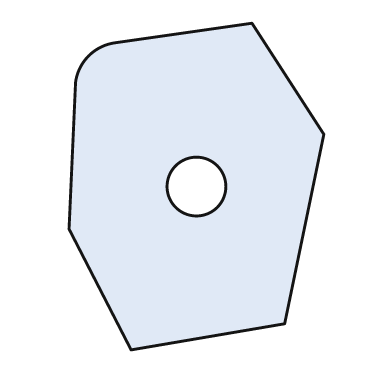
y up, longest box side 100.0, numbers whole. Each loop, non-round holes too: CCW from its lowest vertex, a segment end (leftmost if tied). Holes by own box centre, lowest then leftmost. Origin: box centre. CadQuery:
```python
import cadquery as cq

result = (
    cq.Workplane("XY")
    .moveTo(-20.0, -50.0)
    .lineTo(27.0, -42.0)
    .lineTo(39.0, 16.0)
    .lineTo(17.0, 50.0)
    .lineTo(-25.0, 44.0)
    .threePointArc((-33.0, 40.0), (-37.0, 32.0))
    .lineTo(-39.0, -13.0)
    .close()
    .moveTo(0.0, 0.0)
    .circle(9.0)
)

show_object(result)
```